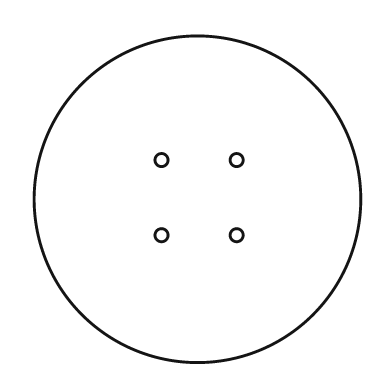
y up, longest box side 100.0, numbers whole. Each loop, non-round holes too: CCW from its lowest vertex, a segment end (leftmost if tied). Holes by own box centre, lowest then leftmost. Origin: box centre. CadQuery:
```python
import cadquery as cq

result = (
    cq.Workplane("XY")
    .moveTo(0.0, 0.0)
    .circle(50.0)
    .moveTo(-11.0, -11.0)
    .circle(2.0)
    .moveTo(12.0, -11.0)
    .circle(2.0)
    .moveTo(-11.0, 12.0)
    .circle(2.0)
    .moveTo(12.0, 12.0)
    .circle(2.0)
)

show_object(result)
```